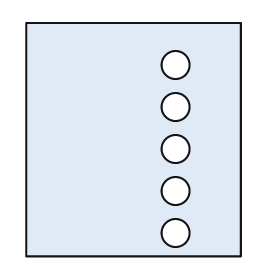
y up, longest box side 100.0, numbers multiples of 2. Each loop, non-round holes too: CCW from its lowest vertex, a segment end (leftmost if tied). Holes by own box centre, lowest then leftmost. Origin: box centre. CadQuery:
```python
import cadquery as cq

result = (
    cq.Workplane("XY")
    .moveTo(-46.0, -50.0)
    .lineTo(46.0, -50.0)
    .lineTo(46.0, 50.0)
    .lineTo(-46.0, 50.0)
    .close()
    .moveTo(18.0, -40.0)
    .circle(6.0)
    .moveTo(18.0, -22.0)
    .circle(6.0)
    .moveTo(18.0, -4.0)
    .circle(6.0)
    .moveTo(18.0, 14.0)
    .circle(6.0)
    .moveTo(18.0, 32.0)
    .circle(6.0)
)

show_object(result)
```